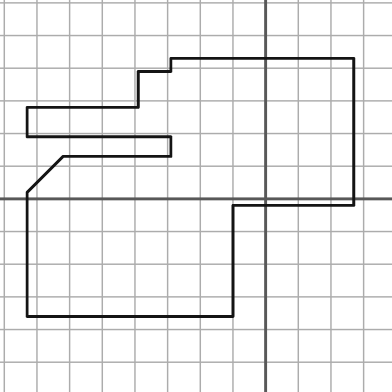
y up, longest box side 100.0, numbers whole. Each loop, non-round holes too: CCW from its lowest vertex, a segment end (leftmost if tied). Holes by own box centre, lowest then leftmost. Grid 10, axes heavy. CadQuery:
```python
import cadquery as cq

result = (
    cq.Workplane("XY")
    .moveTo(-73.0, -36.0)
    .lineTo(-10.0, -36.0)
    .lineTo(-10.0, -2.0)
    .lineTo(27.0, -2.0)
    .lineTo(27.0, 43.0)
    .lineTo(-29.0, 43.0)
    .lineTo(-29.0, 39.0)
    .lineTo(-39.0, 39.0)
    .lineTo(-39.0, 28.0)
    .lineTo(-73.0, 28.0)
    .lineTo(-73.0, 19.0)
    .lineTo(-29.0, 19.0)
    .lineTo(-29.0, 13.0)
    .lineTo(-62.0, 13.0)
    .lineTo(-73.0, 2.0)
    .close()
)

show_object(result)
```